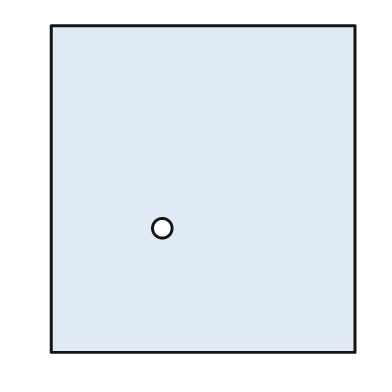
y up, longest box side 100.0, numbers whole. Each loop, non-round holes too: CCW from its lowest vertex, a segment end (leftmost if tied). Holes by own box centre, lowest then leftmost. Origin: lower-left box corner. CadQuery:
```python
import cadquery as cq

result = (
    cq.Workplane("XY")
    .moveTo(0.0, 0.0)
    .lineTo(93.0, 0.0)
    .lineTo(93.0, 100.0)
    .lineTo(0.0, 100.0)
    .close()
    .moveTo(34.0, 38.0)
    .circle(3.0)
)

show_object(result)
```